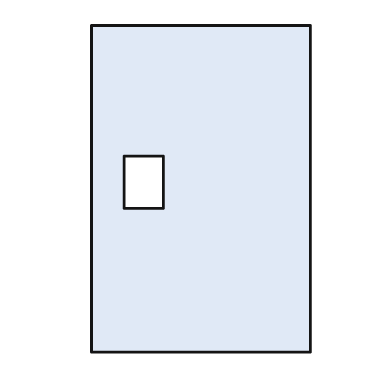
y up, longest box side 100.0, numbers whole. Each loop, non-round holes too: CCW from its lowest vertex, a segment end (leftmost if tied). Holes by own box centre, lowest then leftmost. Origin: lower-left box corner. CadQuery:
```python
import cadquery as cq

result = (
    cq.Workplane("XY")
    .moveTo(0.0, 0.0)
    .lineTo(67.0, 0.0)
    .lineTo(67.0, 100.0)
    .lineTo(0.0, 100.0)
    .close()
    .moveTo(10.0, 44.0)
    .lineTo(22.0, 44.0)
    .lineTo(22.0, 60.0)
    .lineTo(10.0, 60.0)
    .close()
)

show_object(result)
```